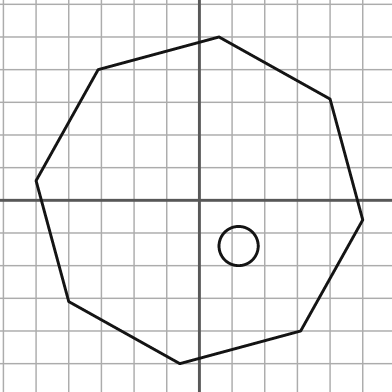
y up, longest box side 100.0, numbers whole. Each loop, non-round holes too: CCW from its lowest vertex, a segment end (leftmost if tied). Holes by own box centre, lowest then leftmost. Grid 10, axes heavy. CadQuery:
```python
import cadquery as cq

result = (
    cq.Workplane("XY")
    .moveTo(-6.0, -50.0)
    .lineTo(31.0, -40.0)
    .lineTo(50.0, -6.0)
    .lineTo(40.0, 31.0)
    .lineTo(6.0, 50.0)
    .lineTo(-31.0, 40.0)
    .lineTo(-50.0, 6.0)
    .lineTo(-40.0, -31.0)
    .close()
    .moveTo(12.0, -14.0)
    .circle(6.0)
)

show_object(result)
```